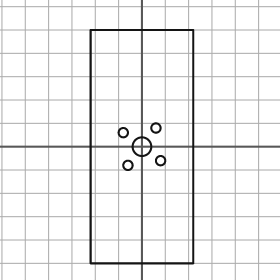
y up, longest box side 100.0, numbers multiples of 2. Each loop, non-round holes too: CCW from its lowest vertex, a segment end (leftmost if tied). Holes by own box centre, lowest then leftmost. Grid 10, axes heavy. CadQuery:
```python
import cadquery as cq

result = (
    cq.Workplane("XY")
    .moveTo(-22.0, -50.0)
    .lineTo(22.0, -50.0)
    .lineTo(22.0, 50.0)
    .lineTo(-22.0, 50.0)
    .close()
    .moveTo(-6.0, -8.0)
    .circle(2.0)
    .moveTo(8.0, -6.0)
    .circle(2.0)
    .moveTo(0.0, 0.0)
    .circle(4.0)
    .moveTo(-8.0, 6.0)
    .circle(2.0)
    .moveTo(6.0, 8.0)
    .circle(2.0)
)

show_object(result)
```